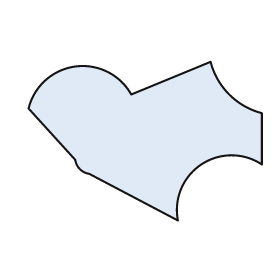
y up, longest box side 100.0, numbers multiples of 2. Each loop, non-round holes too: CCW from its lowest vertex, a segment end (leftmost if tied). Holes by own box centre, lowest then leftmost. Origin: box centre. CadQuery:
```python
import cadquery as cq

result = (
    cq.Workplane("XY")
    .moveTo(14.0, -34.0)
    .threePointArc((24.0, -10.0), (50.0, -10.0))
    .lineTo(50.0, 12.0)
    .threePointArc((36.0, 20.0), (28.0, 34.0))
    .lineTo(-6.0, 20.0)
    .threePointArc((-30.0, 32.0), (-50.0, 14.0))
    .lineTo(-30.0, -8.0)
    .threePointArc((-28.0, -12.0), (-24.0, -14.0))
    .close()
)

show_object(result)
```